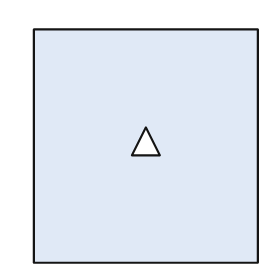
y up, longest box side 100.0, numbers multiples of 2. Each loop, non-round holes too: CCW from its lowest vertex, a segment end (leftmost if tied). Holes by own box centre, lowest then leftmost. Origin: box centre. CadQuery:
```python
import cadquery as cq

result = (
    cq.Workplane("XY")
    .moveTo(-48.0, -50.0)
    .lineTo(48.0, -50.0)
    .lineTo(48.0, 50.0)
    .lineTo(-48.0, 50.0)
    .close()
    .moveTo(-6.0, -4.0)
    .lineTo(6.0, -4.0)
    .lineTo(0.0, 8.0)
    .close()
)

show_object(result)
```